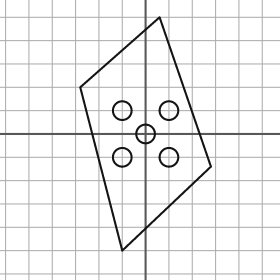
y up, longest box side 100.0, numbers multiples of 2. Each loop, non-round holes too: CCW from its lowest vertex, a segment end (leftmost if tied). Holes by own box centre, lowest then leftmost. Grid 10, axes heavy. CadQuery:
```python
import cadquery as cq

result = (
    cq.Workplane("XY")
    .moveTo(-10.0, -50.0)
    .lineTo(28.0, -14.0)
    .lineTo(6.0, 50.0)
    .lineTo(-28.0, 20.0)
    .close()
    .moveTo(-10.0, -10.0)
    .circle(4.0)
    .moveTo(10.0, -10.0)
    .circle(4.0)
    .moveTo(0.0, 0.0)
    .circle(4.0)
    .moveTo(-10.0, 10.0)
    .circle(4.0)
    .moveTo(10.0, 10.0)
    .circle(4.0)
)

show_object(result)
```